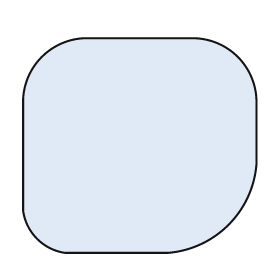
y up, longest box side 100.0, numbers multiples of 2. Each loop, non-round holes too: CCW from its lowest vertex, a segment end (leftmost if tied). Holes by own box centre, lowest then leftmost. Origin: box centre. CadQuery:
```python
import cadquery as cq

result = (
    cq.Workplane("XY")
    .moveTo(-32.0, -46.0)
    .lineTo(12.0, -46.0)
    .threePointArc((38.0, -34.0), (50.0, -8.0))
    .lineTo(50.0, 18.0)
    .threePointArc((42.0, 38.0), (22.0, 46.0))
    .lineTo(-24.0, 46.0)
    .threePointArc((-42.0, 38.0), (-50.0, 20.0))
    .lineTo(-50.0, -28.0)
    .threePointArc((-44.0, -40.0), (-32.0, -46.0))
    .close()
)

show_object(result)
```